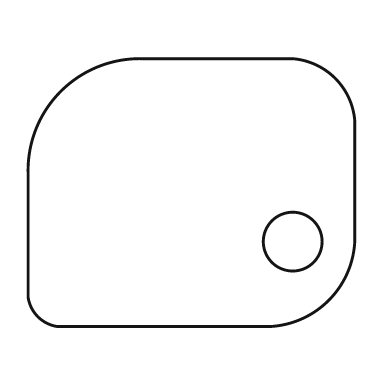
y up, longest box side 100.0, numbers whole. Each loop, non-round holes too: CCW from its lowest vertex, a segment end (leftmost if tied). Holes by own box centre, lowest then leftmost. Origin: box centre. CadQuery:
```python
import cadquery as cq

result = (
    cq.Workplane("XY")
    .moveTo(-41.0, -41.0)
    .lineTo(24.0, -41.0)
    .threePointArc((42.0, -33.0), (50.0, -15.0))
    .lineTo(50.0, 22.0)
    .threePointArc((44.0, 35.0), (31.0, 41.0))
    .lineTo(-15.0, 41.0)
    .threePointArc((-40.0, 31.0), (-50.0, 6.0))
    .lineTo(-50.0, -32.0)
    .threePointArc((-47.0, -38.0), (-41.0, -41.0))
    .close()
    .moveTo(31.0, -15.0)
    .circle(9.0)
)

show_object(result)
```